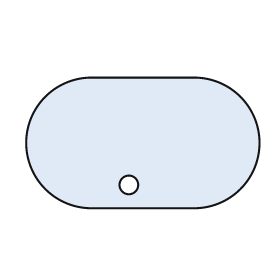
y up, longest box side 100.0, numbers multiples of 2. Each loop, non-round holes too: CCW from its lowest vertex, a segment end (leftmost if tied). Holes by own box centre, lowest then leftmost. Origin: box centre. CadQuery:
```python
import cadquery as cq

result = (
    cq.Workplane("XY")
    .moveTo(-22.0, -28.0)
    .lineTo(22.0, -28.0)
    .threePointArc((50.0, 0.0), (22.0, 28.0))
    .lineTo(-22.0, 28.0)
    .threePointArc((-50.0, 0.0), (-22.0, -28.0))
    .close()
    .moveTo(-6.0, -18.0)
    .circle(4.0)
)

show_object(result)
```